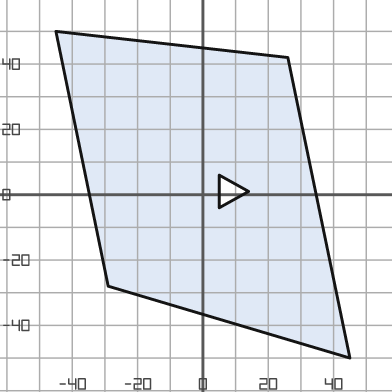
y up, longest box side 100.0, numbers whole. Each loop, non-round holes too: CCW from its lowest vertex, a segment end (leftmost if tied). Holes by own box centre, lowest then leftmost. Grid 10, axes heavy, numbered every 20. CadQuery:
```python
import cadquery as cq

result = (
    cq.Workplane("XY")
    .moveTo(45.0, -50.0)
    .lineTo(26.0, 42.0)
    .lineTo(-45.0, 50.0)
    .lineTo(-29.0, -28.0)
    .close()
    .moveTo(5.0, -4.0)
    .lineTo(14.0, 1.0)
    .lineTo(5.0, 6.0)
    .close()
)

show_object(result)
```